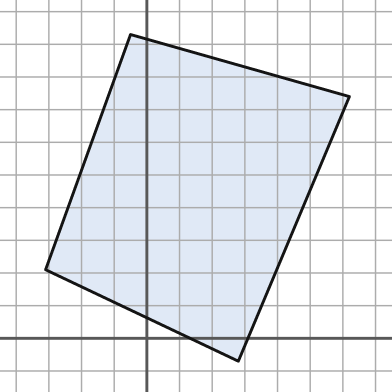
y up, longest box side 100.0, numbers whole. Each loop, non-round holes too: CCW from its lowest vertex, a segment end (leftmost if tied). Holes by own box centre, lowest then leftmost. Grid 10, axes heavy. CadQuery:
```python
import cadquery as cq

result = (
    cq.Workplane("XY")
    .moveTo(28.0, -7.0)
    .lineTo(62.0, 74.0)
    .lineTo(-5.0, 93.0)
    .lineTo(-31.0, 21.0)
    .close()
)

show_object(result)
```